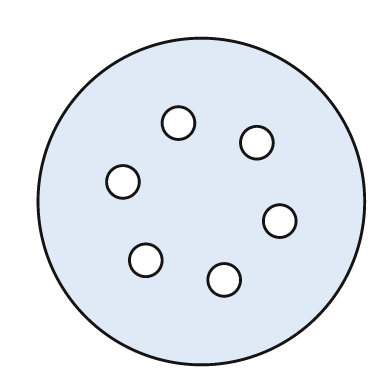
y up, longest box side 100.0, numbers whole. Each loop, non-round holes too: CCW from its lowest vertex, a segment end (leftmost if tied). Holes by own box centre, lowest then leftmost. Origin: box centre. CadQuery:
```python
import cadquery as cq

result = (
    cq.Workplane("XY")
    .moveTo(0.0, 0.0)
    .circle(50.0)
    .moveTo(7.0, -24.0)
    .circle(5.0)
    .moveTo(-17.0, -18.0)
    .circle(5.0)
    .moveTo(24.0, -6.0)
    .circle(5.0)
    .moveTo(-24.0, 6.0)
    .circle(5.0)
    .moveTo(17.0, 18.0)
    .circle(5.0)
    .moveTo(-7.0, 24.0)
    .circle(5.0)
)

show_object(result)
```